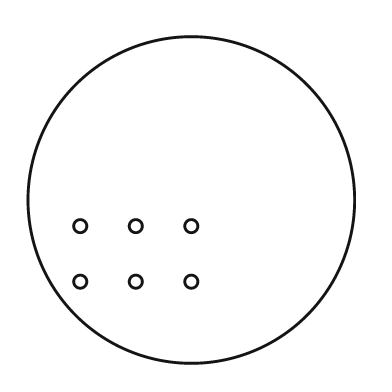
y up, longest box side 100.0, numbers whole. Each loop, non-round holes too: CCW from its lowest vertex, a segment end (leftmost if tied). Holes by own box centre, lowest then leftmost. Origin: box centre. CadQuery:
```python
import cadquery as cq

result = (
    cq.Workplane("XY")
    .moveTo(0.0, 0.0)
    .circle(50.0)
    .moveTo(-34.0, -25.0)
    .circle(2.0)
    .moveTo(-17.0, -25.0)
    .circle(2.0)
    .moveTo(0.0, -25.0)
    .circle(2.0)
    .moveTo(-34.0, -8.0)
    .circle(2.0)
    .moveTo(-17.0, -8.0)
    .circle(2.0)
    .moveTo(0.0, -8.0)
    .circle(2.0)
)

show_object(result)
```